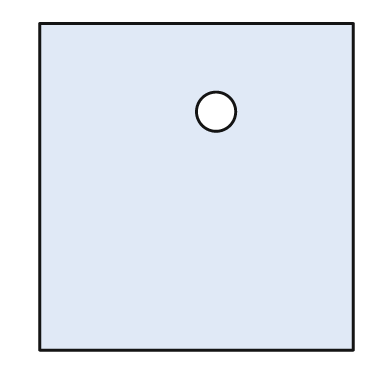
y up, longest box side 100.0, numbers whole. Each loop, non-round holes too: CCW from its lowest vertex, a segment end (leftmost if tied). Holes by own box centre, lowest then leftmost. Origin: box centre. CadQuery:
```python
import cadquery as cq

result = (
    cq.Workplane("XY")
    .moveTo(-48.0, -50.0)
    .lineTo(48.0, -50.0)
    .lineTo(48.0, 50.0)
    .lineTo(-48.0, 50.0)
    .close()
    .moveTo(6.0, 23.0)
    .circle(6.0)
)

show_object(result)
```